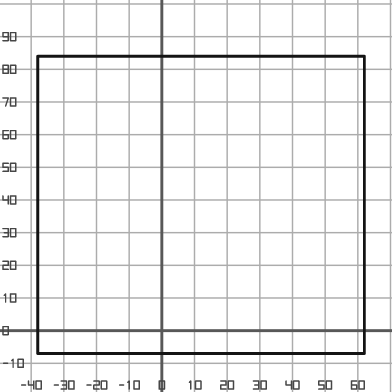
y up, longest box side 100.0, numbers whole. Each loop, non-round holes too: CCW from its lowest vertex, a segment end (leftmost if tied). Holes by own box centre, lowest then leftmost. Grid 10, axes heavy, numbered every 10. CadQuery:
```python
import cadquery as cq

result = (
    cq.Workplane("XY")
    .moveTo(-38.0, -7.0)
    .lineTo(62.0, -7.0)
    .lineTo(62.0, 84.0)
    .lineTo(-38.0, 84.0)
    .close()
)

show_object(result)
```